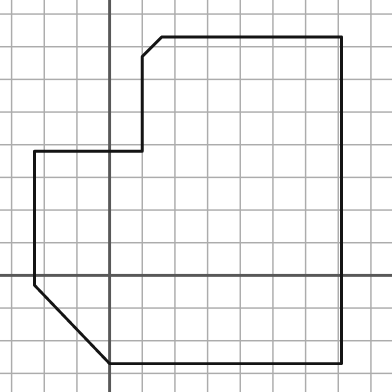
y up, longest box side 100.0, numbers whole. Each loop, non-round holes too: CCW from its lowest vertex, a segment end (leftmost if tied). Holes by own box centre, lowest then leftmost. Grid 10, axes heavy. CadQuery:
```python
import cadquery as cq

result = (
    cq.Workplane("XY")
    .moveTo(0.0, -27.0)
    .lineTo(71.0, -27.0)
    .lineTo(71.0, 73.0)
    .lineTo(16.0, 73.0)
    .lineTo(10.0, 67.0)
    .lineTo(10.0, 38.0)
    .lineTo(-23.0, 38.0)
    .lineTo(-23.0, -3.0)
    .close()
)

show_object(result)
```